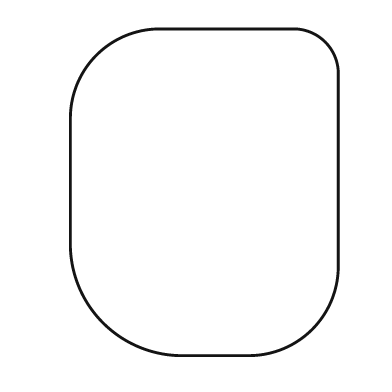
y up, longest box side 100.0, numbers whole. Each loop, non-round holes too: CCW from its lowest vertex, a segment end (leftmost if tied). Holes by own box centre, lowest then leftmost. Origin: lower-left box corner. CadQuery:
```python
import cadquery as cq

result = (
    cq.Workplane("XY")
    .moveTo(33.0, 0.0)
    .lineTo(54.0, 0.0)
    .threePointArc((74.0, 8.0), (82.0, 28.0))
    .lineTo(82.0, 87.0)
    .threePointArc((78.0, 96.0), (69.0, 100.0))
    .lineTo(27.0, 100.0)
    .threePointArc((8.0, 92.0), (0.0, 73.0))
    .lineTo(0.0, 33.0)
    .threePointArc((10.0, 10.0), (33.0, 0.0))
    .close()
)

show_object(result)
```